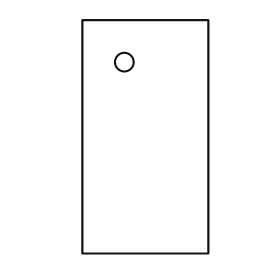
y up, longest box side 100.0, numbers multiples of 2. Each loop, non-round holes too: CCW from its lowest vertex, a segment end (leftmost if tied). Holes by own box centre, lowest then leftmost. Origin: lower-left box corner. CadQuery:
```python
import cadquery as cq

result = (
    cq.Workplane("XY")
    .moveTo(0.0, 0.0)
    .lineTo(54.0, 0.0)
    .lineTo(54.0, 100.0)
    .lineTo(0.0, 100.0)
    .close()
    .moveTo(18.0, 82.0)
    .circle(4.0)
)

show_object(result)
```